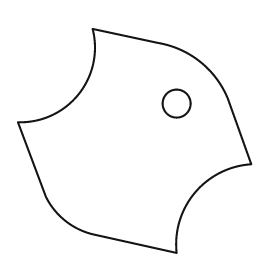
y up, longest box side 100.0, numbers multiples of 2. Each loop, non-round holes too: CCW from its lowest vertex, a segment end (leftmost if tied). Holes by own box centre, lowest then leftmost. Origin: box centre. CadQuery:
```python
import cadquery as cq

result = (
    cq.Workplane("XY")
    .moveTo(18.0, -48.0)
    .threePointArc((26.0, -22.0), (50.0, -10.0))
    .lineTo(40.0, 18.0)
    .threePointArc((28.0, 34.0), (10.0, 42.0))
    .lineTo(-18.0, 48.0)
    .threePointArc((-24.0, 20.0), (-50.0, 8.0))
    .lineTo(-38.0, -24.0)
    .threePointArc((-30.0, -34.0), (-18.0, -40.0))
    .close()
    .moveTo(18.0, 16.0)
    .circle(6.0)
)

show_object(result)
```